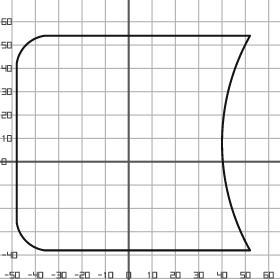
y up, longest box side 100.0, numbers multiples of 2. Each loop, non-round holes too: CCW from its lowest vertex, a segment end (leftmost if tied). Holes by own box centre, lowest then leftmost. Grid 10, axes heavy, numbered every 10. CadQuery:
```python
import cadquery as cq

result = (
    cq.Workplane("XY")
    .moveTo(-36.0, -38.0)
    .lineTo(52.0, -38.0)
    .threePointArc((40.0, 8.0), (52.0, 54.0))
    .lineTo(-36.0, 54.0)
    .threePointArc((-44.0, 50.0), (-48.0, 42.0))
    .lineTo(-48.0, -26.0)
    .threePointArc((-44.0, -34.0), (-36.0, -38.0))
    .close()
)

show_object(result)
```